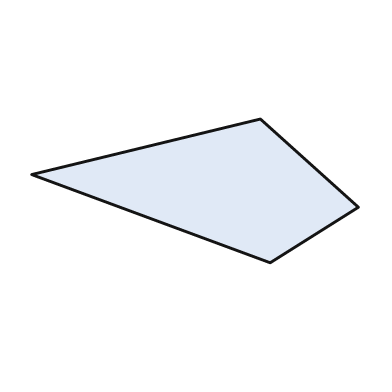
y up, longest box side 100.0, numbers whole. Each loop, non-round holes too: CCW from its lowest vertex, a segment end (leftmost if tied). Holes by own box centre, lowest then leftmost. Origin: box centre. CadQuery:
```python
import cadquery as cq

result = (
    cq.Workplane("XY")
    .moveTo(23.0, -22.0)
    .lineTo(50.0, -5.0)
    .lineTo(20.0, 22.0)
    .lineTo(-50.0, 5.0)
    .close()
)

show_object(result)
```